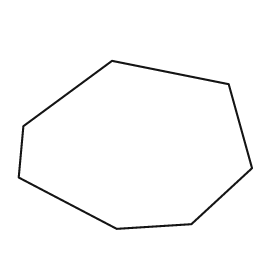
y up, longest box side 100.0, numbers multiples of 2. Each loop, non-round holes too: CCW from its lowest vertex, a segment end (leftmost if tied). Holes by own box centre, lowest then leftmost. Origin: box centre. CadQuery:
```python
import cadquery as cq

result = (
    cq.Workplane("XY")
    .moveTo(-8.0, -36.0)
    .lineTo(24.0, -34.0)
    .lineTo(50.0, -10.0)
    .lineTo(40.0, 26.0)
    .lineTo(-10.0, 36.0)
    .lineTo(-48.0, 8.0)
    .lineTo(-50.0, -14.0)
    .close()
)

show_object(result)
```